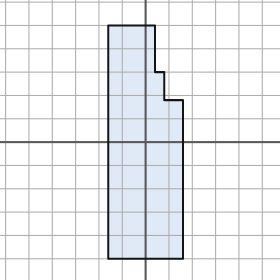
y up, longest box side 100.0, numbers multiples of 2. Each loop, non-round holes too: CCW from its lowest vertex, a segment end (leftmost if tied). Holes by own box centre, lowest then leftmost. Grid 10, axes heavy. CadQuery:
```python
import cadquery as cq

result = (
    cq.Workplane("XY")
    .moveTo(-16.0, -50.0)
    .lineTo(16.0, -50.0)
    .lineTo(16.0, 18.0)
    .lineTo(8.0, 18.0)
    .lineTo(8.0, 30.0)
    .lineTo(4.0, 30.0)
    .lineTo(4.0, 50.0)
    .lineTo(-16.0, 50.0)
    .close()
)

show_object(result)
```